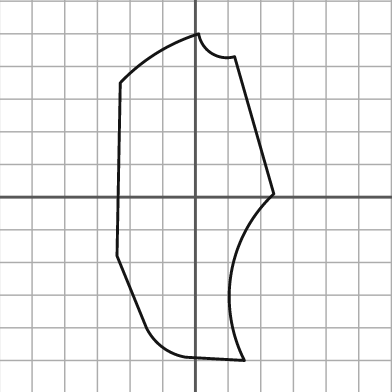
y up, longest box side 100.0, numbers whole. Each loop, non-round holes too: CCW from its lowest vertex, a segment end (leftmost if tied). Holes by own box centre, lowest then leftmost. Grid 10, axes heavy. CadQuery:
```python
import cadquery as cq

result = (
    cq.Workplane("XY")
    .moveTo(15.0, -50.0)
    .threePointArc((11.0, -23.0), (24.0, 1.0))
    .lineTo(12.0, 43.0)
    .threePointArc((5.0, 44.0), (1.0, 50.0))
    .threePointArc((-12.0, 44.0), (-23.0, 35.0))
    .lineTo(-24.0, -18.0)
    .lineTo(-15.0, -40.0)
    .threePointArc((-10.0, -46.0), (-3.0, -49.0))
    .close()
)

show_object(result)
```